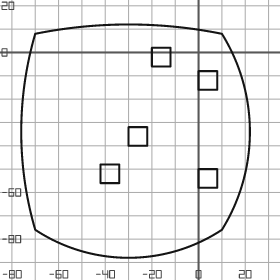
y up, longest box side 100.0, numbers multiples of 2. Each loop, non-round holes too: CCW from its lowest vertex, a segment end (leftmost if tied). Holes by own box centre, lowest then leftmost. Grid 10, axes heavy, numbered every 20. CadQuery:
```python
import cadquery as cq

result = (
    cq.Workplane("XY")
    .moveTo(-70.0, -76.0)
    .threePointArc((-30.0, -88.0), (10.0, -76.0))
    .threePointArc((22.0, -34.0), (10.0, 8.0))
    .threePointArc((-30.0, 12.0), (-70.0, 8.0))
    .threePointArc((-76.0, -34.0), (-70.0, -76.0))
    .close()
    .moveTo(0.0, -58.0)
    .lineTo(8.0, -58.0)
    .lineTo(8.0, -50.0)
    .lineTo(0.0, -50.0)
    .close()
    .moveTo(-42.0, -56.0)
    .lineTo(-34.0, -56.0)
    .lineTo(-34.0, -48.0)
    .lineTo(-42.0, -48.0)
    .close()
    .moveTo(-30.0, -40.0)
    .lineTo(-22.0, -40.0)
    .lineTo(-22.0, -32.0)
    .lineTo(-30.0, -32.0)
    .close()
    .moveTo(0.0, -16.0)
    .lineTo(8.0, -16.0)
    .lineTo(8.0, -8.0)
    .lineTo(0.0, -8.0)
    .close()
    .moveTo(-20.0, -6.0)
    .lineTo(-12.0, -6.0)
    .lineTo(-12.0, 2.0)
    .lineTo(-20.0, 2.0)
    .close()
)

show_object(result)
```